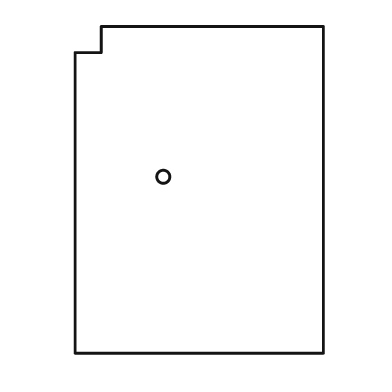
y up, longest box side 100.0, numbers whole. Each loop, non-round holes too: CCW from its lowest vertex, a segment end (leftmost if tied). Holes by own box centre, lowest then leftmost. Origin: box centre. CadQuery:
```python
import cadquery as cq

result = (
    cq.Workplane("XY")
    .moveTo(-38.0, -50.0)
    .lineTo(38.0, -50.0)
    .lineTo(38.0, 50.0)
    .lineTo(-30.0, 50.0)
    .lineTo(-30.0, 42.0)
    .lineTo(-38.0, 42.0)
    .close()
    .moveTo(-11.0, 4.0)
    .circle(2.0)
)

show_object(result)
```